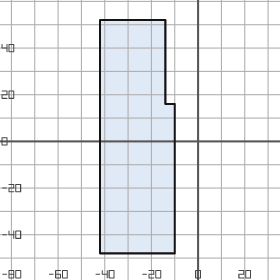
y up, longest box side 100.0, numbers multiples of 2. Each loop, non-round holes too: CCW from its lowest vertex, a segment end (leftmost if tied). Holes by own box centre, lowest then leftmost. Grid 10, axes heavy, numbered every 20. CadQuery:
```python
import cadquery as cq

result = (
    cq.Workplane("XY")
    .moveTo(-42.0, -48.0)
    .lineTo(-10.0, -48.0)
    .lineTo(-10.0, 16.0)
    .lineTo(-14.0, 16.0)
    .lineTo(-14.0, 52.0)
    .lineTo(-42.0, 52.0)
    .close()
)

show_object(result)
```